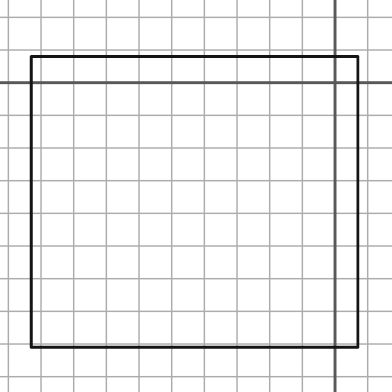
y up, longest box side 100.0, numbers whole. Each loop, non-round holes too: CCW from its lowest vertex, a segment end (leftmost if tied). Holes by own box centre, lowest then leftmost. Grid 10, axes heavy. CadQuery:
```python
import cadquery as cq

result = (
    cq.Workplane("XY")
    .moveTo(-93.0, -81.0)
    .lineTo(7.0, -81.0)
    .lineTo(7.0, 8.0)
    .lineTo(-93.0, 8.0)
    .close()
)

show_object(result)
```